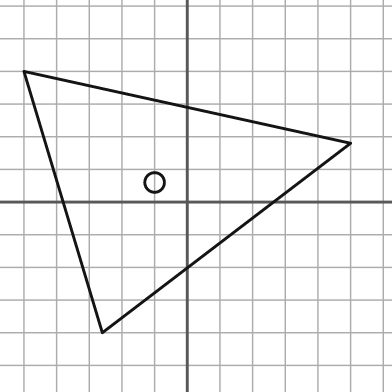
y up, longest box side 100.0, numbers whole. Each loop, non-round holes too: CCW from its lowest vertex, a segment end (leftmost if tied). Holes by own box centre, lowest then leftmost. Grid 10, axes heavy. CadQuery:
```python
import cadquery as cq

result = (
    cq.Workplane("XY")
    .moveTo(-26.0, -40.0)
    .lineTo(50.0, 18.0)
    .lineTo(-50.0, 40.0)
    .close()
    .moveTo(-10.0, 6.0)
    .circle(3.0)
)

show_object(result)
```